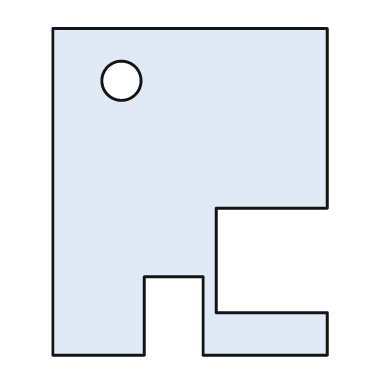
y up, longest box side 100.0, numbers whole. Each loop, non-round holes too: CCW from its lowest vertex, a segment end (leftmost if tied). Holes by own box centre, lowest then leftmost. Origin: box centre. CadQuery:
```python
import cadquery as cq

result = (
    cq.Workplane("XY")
    .moveTo(-42.0, -50.0)
    .lineTo(-14.0, -50.0)
    .lineTo(-14.0, -26.0)
    .lineTo(4.0, -26.0)
    .lineTo(4.0, -50.0)
    .lineTo(42.0, -50.0)
    .lineTo(42.0, -37.0)
    .lineTo(8.0, -37.0)
    .lineTo(8.0, -5.0)
    .lineTo(42.0, -5.0)
    .lineTo(42.0, 50.0)
    .lineTo(-42.0, 50.0)
    .close()
    .moveTo(-21.0, 34.0)
    .circle(6.0)
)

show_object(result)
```